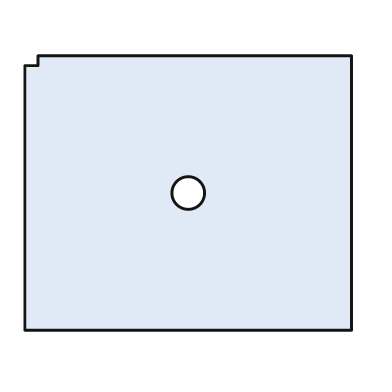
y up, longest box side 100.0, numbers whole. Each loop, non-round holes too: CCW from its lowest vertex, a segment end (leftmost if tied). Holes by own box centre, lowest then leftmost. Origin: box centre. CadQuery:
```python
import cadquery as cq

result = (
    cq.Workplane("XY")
    .moveTo(-50.0, -42.0)
    .lineTo(50.0, -42.0)
    .lineTo(50.0, 42.0)
    .lineTo(-46.0, 42.0)
    .lineTo(-46.0, 39.0)
    .lineTo(-50.0, 39.0)
    .close()
    .moveTo(0.0, 0.0)
    .circle(5.0)
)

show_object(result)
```